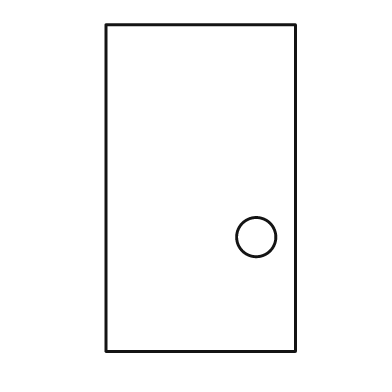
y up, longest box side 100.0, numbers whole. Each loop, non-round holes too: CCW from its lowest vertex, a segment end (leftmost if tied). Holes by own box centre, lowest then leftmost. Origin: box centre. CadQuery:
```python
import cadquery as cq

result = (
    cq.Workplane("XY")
    .moveTo(-29.0, -50.0)
    .lineTo(29.0, -50.0)
    .lineTo(29.0, 50.0)
    .lineTo(-29.0, 50.0)
    .close()
    .moveTo(17.0, -15.0)
    .circle(6.0)
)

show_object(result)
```